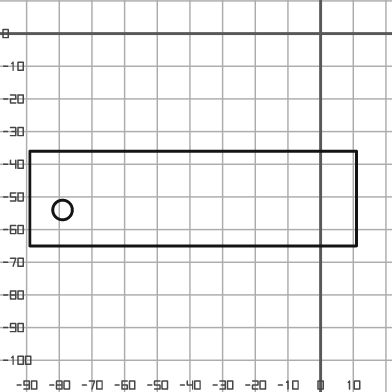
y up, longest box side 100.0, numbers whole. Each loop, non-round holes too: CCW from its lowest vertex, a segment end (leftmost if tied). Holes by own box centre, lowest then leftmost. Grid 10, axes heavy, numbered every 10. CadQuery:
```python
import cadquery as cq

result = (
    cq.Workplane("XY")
    .moveTo(-89.0, -65.0)
    .lineTo(11.0, -65.0)
    .lineTo(11.0, -36.0)
    .lineTo(-89.0, -36.0)
    .close()
    .moveTo(-79.0, -54.0)
    .circle(3.0)
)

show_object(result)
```